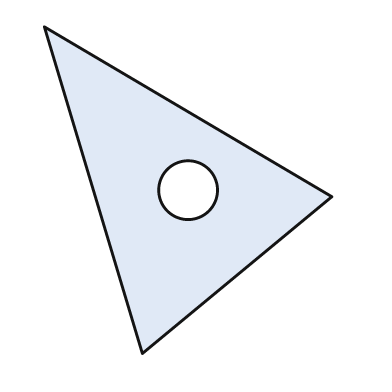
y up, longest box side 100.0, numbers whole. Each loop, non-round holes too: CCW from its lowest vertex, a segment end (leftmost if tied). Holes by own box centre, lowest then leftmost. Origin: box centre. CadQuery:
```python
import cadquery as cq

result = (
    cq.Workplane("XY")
    .moveTo(-14.0, -50.0)
    .lineTo(44.0, -2.0)
    .lineTo(-44.0, 50.0)
    .close()
    .moveTo(0.0, 0.0)
    .circle(9.0)
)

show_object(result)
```